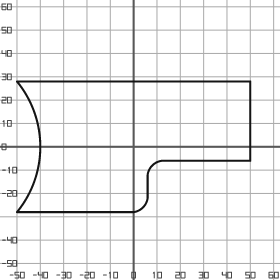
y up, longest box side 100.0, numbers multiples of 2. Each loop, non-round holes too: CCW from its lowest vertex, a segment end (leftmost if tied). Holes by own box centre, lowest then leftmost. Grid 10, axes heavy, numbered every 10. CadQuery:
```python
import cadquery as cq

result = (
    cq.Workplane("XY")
    .moveTo(-50.0, -28.0)
    .lineTo(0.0, -28.0)
    .threePointArc((4.0, -26.0), (6.0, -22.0))
    .lineTo(6.0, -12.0)
    .threePointArc((8.0, -8.0), (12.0, -6.0))
    .lineTo(50.0, -6.0)
    .lineTo(50.0, 28.0)
    .lineTo(-50.0, 28.0)
    .threePointArc((-40.0, 0.0), (-50.0, -28.0))
    .close()
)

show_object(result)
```